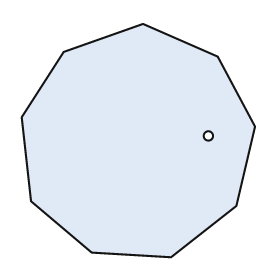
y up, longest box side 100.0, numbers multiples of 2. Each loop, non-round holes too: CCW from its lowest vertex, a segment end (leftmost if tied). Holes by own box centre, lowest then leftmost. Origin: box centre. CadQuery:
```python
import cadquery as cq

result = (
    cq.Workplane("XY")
    .moveTo(14.0, -50.0)
    .lineTo(42.0, -28.0)
    .lineTo(50.0, 6.0)
    .lineTo(34.0, 36.0)
    .lineTo(2.0, 50.0)
    .lineTo(-32.0, 38.0)
    .lineTo(-50.0, 10.0)
    .lineTo(-46.0, -26.0)
    .lineTo(-20.0, -48.0)
    .close()
    .moveTo(30.0, 2.0)
    .circle(2.0)
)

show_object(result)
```